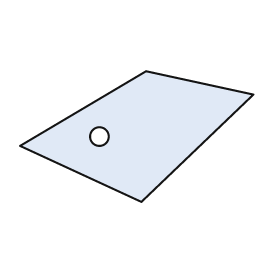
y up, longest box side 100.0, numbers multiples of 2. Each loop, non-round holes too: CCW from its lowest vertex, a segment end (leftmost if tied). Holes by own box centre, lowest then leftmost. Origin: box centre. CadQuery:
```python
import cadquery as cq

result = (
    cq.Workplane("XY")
    .moveTo(2.0, -28.0)
    .lineTo(50.0, 18.0)
    .lineTo(4.0, 28.0)
    .lineTo(-50.0, -4.0)
    .close()
    .moveTo(-16.0, 0.0)
    .circle(4.0)
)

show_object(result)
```